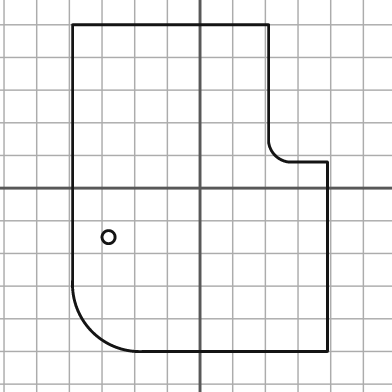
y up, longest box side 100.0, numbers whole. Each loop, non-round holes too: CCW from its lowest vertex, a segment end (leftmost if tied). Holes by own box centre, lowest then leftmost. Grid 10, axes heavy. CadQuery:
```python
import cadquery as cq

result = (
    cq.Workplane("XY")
    .moveTo(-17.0, -50.0)
    .lineTo(39.0, -50.0)
    .lineTo(39.0, 8.0)
    .lineTo(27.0, 8.0)
    .threePointArc((23.0, 10.0), (21.0, 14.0))
    .lineTo(21.0, 50.0)
    .lineTo(-39.0, 50.0)
    .lineTo(-39.0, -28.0)
    .threePointArc((-33.0, -44.0), (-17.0, -50.0))
    .close()
    .moveTo(-28.0, -15.0)
    .circle(2.0)
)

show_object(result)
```